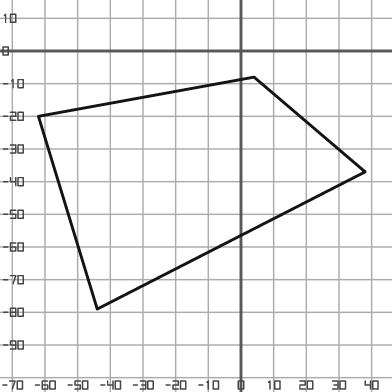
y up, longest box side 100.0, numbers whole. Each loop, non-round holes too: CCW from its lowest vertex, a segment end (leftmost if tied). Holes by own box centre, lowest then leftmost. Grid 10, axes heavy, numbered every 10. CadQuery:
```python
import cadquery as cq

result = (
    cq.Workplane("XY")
    .moveTo(-44.0, -79.0)
    .lineTo(38.0, -37.0)
    .lineTo(4.0, -8.0)
    .lineTo(-62.0, -20.0)
    .close()
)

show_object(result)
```